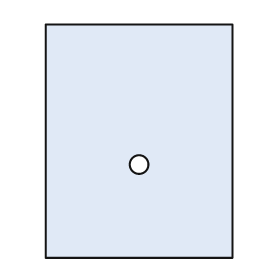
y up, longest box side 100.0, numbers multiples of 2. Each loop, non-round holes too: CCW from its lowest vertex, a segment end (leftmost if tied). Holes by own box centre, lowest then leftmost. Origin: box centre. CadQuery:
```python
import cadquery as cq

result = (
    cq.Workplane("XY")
    .moveTo(-40.0, -50.0)
    .lineTo(40.0, -50.0)
    .lineTo(40.0, 50.0)
    .lineTo(-40.0, 50.0)
    .close()
    .moveTo(0.0, -10.0)
    .circle(4.0)
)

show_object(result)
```